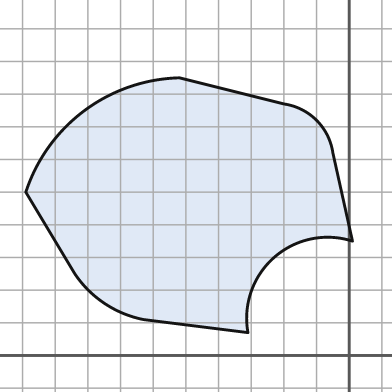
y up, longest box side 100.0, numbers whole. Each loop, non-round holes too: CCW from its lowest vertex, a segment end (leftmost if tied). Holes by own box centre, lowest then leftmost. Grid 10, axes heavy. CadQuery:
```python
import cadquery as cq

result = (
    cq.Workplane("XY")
    .moveTo(-31.0, 7.0)
    .threePointArc((-23.0, 30.0), (1.0, 35.0))
    .lineTo(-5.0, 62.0)
    .threePointArc((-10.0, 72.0), (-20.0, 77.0))
    .lineTo(-52.0, 85.0)
    .threePointArc((-81.0, 75.0), (-99.0, 50.0))
    .lineTo(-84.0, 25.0)
    .threePointArc((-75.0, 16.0), (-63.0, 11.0))
    .close()
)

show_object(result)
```